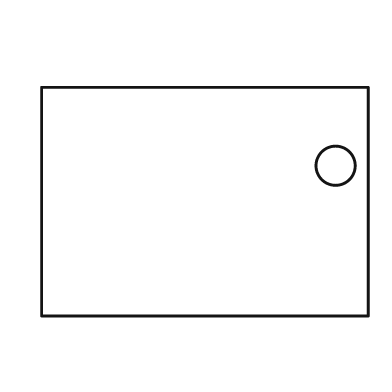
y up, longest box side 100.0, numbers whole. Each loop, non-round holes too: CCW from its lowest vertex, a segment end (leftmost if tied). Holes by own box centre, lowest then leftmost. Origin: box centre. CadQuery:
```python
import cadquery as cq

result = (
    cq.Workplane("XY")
    .moveTo(-50.0, -35.0)
    .lineTo(50.0, -35.0)
    .lineTo(50.0, 35.0)
    .lineTo(-50.0, 35.0)
    .close()
    .moveTo(40.0, 11.0)
    .circle(6.0)
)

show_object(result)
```